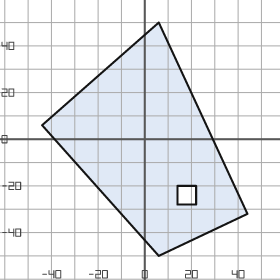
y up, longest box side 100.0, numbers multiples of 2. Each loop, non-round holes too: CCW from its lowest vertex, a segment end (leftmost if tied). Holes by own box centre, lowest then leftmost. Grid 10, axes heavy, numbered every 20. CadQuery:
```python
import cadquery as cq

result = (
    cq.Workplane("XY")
    .moveTo(6.0, -50.0)
    .lineTo(44.0, -32.0)
    .lineTo(6.0, 50.0)
    .lineTo(-44.0, 6.0)
    .close()
    .moveTo(14.0, -28.0)
    .lineTo(22.0, -28.0)
    .lineTo(22.0, -20.0)
    .lineTo(14.0, -20.0)
    .close()
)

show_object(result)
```